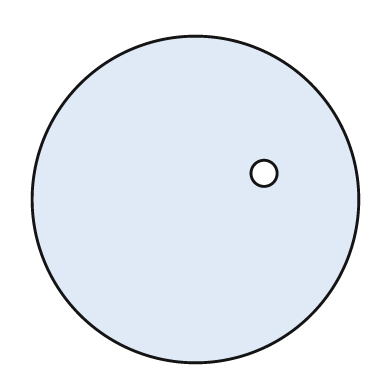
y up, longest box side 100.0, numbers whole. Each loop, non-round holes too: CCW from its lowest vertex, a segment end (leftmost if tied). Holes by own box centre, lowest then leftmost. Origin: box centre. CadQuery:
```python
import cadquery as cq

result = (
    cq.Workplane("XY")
    .moveTo(0.0, 0.0)
    .circle(50.0)
    .moveTo(21.0, 8.0)
    .circle(4.0)
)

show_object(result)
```